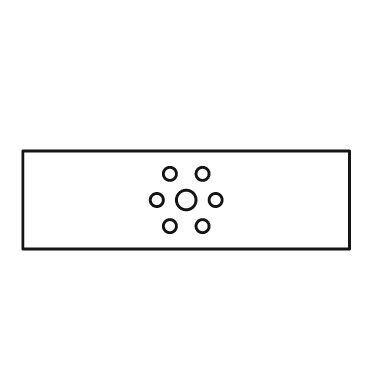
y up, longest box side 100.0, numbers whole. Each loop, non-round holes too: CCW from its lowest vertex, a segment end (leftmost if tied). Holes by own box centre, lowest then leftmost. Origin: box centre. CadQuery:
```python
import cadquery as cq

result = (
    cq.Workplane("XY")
    .moveTo(-50.0, -15.0)
    .lineTo(50.0, -15.0)
    .lineTo(50.0, 15.0)
    .lineTo(-50.0, 15.0)
    .close()
    .moveTo(-5.0, -8.0)
    .circle(2.0)
    .moveTo(5.0, -8.0)
    .circle(2.0)
    .moveTo(-9.0, 0.0)
    .circle(2.0)
    .moveTo(0.0, 0.0)
    .circle(3.0)
    .moveTo(9.0, 0.0)
    .circle(2.0)
    .moveTo(-5.0, 8.0)
    .circle(2.0)
    .moveTo(5.0, 8.0)
    .circle(2.0)
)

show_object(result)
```